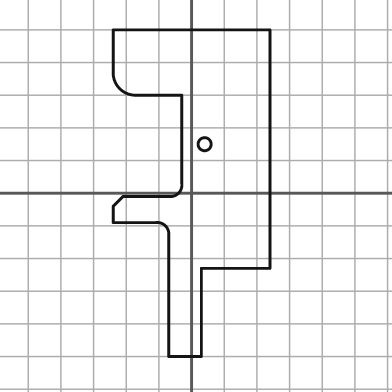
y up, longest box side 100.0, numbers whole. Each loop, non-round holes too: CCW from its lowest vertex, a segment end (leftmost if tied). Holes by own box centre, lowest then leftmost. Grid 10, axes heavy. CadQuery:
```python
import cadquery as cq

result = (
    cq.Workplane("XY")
    .moveTo(-7.0, -50.0)
    .lineTo(3.0, -50.0)
    .lineTo(3.0, -23.0)
    .lineTo(24.0, -23.0)
    .lineTo(24.0, 50.0)
    .lineTo(-24.0, 50.0)
    .lineTo(-24.0, 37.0)
    .threePointArc((-22.0, 32.0), (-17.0, 30.0))
    .lineTo(-3.0, 30.0)
    .lineTo(-3.0, 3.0)
    .threePointArc((-4.0, 0.0), (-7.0, -1.0))
    .lineTo(-21.0, -1.0)
    .lineTo(-24.0, -4.0)
    .lineTo(-24.0, -9.0)
    .lineTo(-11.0, -9.0)
    .threePointArc((-8.0, -10.0), (-7.0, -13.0))
    .close()
    .moveTo(4.0, 15.0)
    .circle(2.0)
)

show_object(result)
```